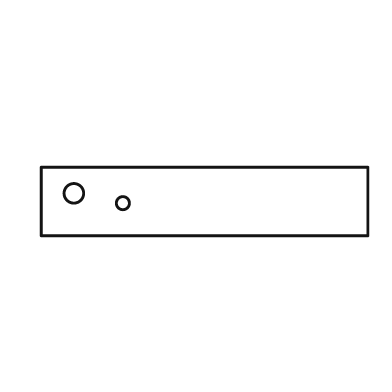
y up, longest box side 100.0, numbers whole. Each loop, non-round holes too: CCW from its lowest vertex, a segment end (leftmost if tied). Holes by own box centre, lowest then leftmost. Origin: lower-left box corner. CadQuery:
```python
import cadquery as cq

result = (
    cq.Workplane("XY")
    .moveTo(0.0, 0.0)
    .lineTo(100.0, 0.0)
    .lineTo(100.0, 21.0)
    .lineTo(0.0, 21.0)
    .close()
    .moveTo(25.0, 10.0)
    .circle(2.0)
    .moveTo(10.0, 13.0)
    .circle(3.0)
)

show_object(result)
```